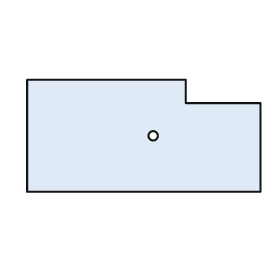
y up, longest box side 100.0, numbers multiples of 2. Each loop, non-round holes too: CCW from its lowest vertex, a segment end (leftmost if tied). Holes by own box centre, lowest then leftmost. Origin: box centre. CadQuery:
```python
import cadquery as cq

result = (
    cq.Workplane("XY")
    .moveTo(-50.0, -24.0)
    .lineTo(50.0, -24.0)
    .lineTo(50.0, 14.0)
    .lineTo(18.0, 14.0)
    .lineTo(18.0, 24.0)
    .lineTo(-50.0, 24.0)
    .close()
    .moveTo(4.0, 0.0)
    .circle(2.0)
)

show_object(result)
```